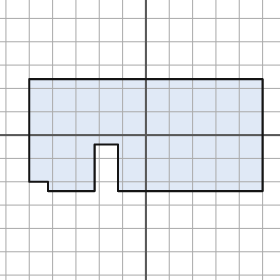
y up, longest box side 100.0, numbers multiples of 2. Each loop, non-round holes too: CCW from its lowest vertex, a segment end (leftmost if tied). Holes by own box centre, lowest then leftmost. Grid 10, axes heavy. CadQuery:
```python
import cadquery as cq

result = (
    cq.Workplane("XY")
    .moveTo(-42.0, -24.0)
    .lineTo(-22.0, -24.0)
    .lineTo(-22.0, -4.0)
    .lineTo(-12.0, -4.0)
    .lineTo(-12.0, -24.0)
    .lineTo(50.0, -24.0)
    .lineTo(50.0, 24.0)
    .lineTo(-50.0, 24.0)
    .lineTo(-50.0, -20.0)
    .lineTo(-42.0, -20.0)
    .close()
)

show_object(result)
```